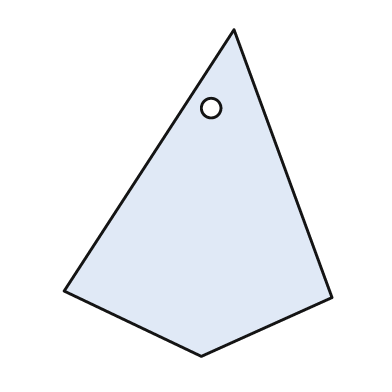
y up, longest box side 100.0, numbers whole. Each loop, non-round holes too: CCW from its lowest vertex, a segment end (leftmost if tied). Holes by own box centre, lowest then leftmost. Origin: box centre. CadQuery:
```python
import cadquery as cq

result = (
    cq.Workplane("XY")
    .moveTo(1.0, -50.0)
    .lineTo(41.0, -32.0)
    .lineTo(11.0, 50.0)
    .lineTo(-41.0, -30.0)
    .close()
    .moveTo(4.0, 26.0)
    .circle(3.0)
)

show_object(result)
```